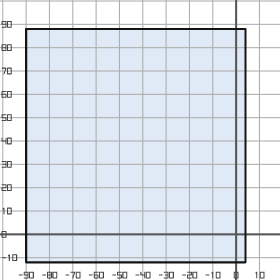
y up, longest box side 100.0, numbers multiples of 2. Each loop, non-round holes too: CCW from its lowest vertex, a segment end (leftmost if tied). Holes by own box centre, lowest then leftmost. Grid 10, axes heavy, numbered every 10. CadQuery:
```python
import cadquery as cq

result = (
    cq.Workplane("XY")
    .moveTo(-90.0, -12.0)
    .lineTo(4.0, -12.0)
    .lineTo(4.0, 88.0)
    .lineTo(-90.0, 88.0)
    .close()
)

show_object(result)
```